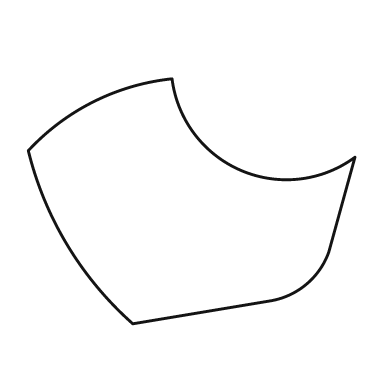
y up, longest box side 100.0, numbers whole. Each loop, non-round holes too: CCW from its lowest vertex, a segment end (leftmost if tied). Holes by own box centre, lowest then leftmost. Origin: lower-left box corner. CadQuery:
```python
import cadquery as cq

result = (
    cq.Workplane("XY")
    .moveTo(32.0, 0.0)
    .lineTo(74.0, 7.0)
    .threePointArc((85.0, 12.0), (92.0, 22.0))
    .lineTo(100.0, 51.0)
    .threePointArc((65.0, 47.0), (44.0, 75.0))
    .threePointArc((20.0, 68.0), (0.0, 53.0))
    .threePointArc((12.0, 24.0), (32.0, 0.0))
    .close()
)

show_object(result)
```